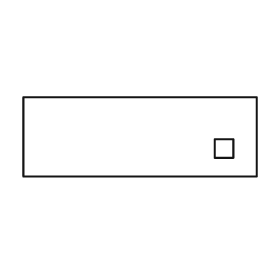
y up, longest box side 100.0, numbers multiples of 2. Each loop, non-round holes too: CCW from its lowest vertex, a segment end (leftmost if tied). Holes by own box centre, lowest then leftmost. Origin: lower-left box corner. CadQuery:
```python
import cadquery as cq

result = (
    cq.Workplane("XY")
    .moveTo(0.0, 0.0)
    .lineTo(100.0, 0.0)
    .lineTo(100.0, 34.0)
    .lineTo(0.0, 34.0)
    .close()
    .moveTo(82.0, 8.0)
    .lineTo(90.0, 8.0)
    .lineTo(90.0, 16.0)
    .lineTo(82.0, 16.0)
    .close()
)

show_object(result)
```